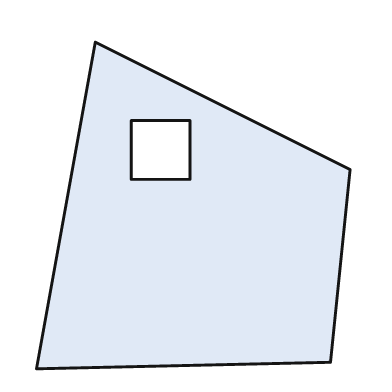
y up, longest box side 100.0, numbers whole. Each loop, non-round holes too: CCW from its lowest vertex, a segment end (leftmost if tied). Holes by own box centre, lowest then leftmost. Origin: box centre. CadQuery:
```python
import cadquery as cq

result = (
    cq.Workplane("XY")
    .moveTo(-48.0, -50.0)
    .lineTo(42.0, -48.0)
    .lineTo(48.0, 11.0)
    .lineTo(-30.0, 50.0)
    .close()
    .moveTo(-19.0, 8.0)
    .lineTo(-1.0, 8.0)
    .lineTo(-1.0, 26.0)
    .lineTo(-19.0, 26.0)
    .close()
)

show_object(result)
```